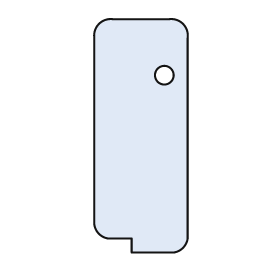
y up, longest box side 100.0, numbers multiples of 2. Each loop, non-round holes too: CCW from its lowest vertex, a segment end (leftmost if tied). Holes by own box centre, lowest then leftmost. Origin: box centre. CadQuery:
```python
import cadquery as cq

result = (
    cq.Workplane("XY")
    .moveTo(-4.0, -50.0)
    .lineTo(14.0, -50.0)
    .threePointArc((18.0, -48.0), (20.0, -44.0))
    .lineTo(20.0, 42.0)
    .threePointArc((18.0, 48.0), (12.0, 50.0))
    .lineTo(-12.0, 50.0)
    .threePointArc((-18.0, 48.0), (-20.0, 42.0))
    .lineTo(-20.0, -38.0)
    .threePointArc((-18.0, -42.0), (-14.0, -44.0))
    .lineTo(-4.0, -44.0)
    .close()
    .moveTo(10.0, 26.0)
    .circle(4.0)
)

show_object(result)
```